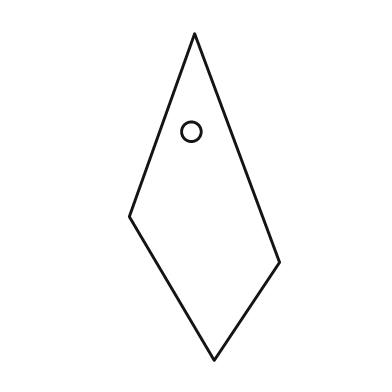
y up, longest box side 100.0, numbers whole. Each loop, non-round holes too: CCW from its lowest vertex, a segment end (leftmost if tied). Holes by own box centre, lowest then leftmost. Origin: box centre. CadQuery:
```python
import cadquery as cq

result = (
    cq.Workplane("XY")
    .moveTo(3.0, -50.0)
    .lineTo(23.0, -20.0)
    .lineTo(-3.0, 50.0)
    .lineTo(-23.0, -6.0)
    .close()
    .moveTo(-4.0, 20.0)
    .circle(3.0)
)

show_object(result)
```